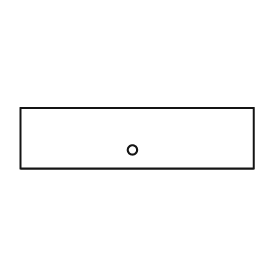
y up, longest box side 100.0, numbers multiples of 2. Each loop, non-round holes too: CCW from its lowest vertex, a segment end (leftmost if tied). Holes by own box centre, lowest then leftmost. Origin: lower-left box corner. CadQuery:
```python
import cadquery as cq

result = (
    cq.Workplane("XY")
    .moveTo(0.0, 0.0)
    .lineTo(100.0, 0.0)
    .lineTo(100.0, 26.0)
    .lineTo(0.0, 26.0)
    .close()
    .moveTo(48.0, 8.0)
    .circle(2.0)
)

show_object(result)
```